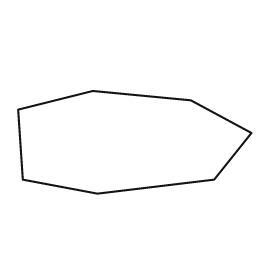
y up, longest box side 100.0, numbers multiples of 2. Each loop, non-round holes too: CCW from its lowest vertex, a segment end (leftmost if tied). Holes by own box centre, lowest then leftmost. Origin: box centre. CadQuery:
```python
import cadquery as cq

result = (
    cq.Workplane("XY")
    .moveTo(-16.0, -22.0)
    .lineTo(34.0, -16.0)
    .lineTo(50.0, 4.0)
    .lineTo(24.0, 18.0)
    .lineTo(-18.0, 22.0)
    .lineTo(-50.0, 14.0)
    .lineTo(-48.0, -16.0)
    .close()
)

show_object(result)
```